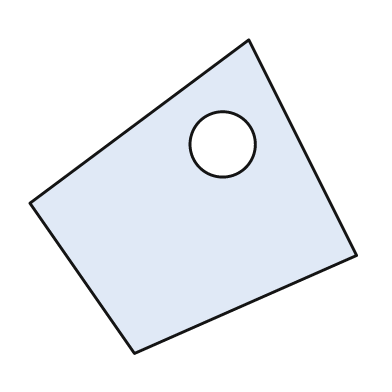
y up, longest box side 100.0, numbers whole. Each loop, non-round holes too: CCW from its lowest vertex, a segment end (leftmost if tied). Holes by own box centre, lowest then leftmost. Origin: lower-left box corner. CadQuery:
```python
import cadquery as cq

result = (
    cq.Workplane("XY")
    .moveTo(32.0, 0.0)
    .lineTo(100.0, 30.0)
    .lineTo(67.0, 96.0)
    .lineTo(0.0, 46.0)
    .close()
    .moveTo(59.0, 64.0)
    .circle(10.0)
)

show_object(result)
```